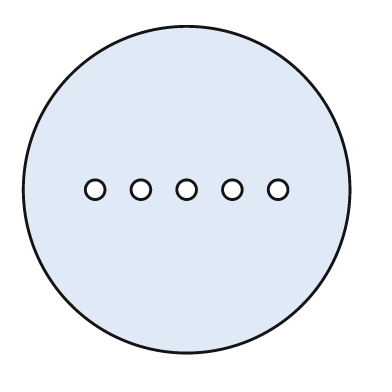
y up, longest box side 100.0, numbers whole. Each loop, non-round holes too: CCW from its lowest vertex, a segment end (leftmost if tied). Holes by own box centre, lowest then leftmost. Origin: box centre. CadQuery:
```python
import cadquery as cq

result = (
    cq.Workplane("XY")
    .moveTo(0.0, 0.0)
    .circle(50.0)
    .moveTo(-28.0, 0.0)
    .circle(3.0)
    .moveTo(-14.0, 0.0)
    .circle(3.0)
    .moveTo(0.0, 0.0)
    .circle(3.0)
    .moveTo(14.0, 0.0)
    .circle(3.0)
    .moveTo(28.0, 0.0)
    .circle(3.0)
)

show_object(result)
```